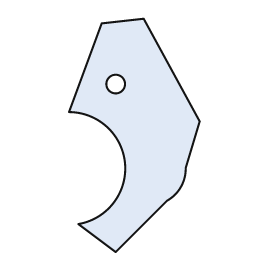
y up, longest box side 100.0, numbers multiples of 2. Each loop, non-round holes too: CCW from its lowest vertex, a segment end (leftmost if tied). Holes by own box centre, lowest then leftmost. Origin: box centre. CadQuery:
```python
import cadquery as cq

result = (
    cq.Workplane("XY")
    .moveTo(-8.0, -50.0)
    .lineTo(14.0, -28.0)
    .threePointArc((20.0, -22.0), (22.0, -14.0))
    .lineTo(28.0, 6.0)
    .lineTo(4.0, 50.0)
    .lineTo(-14.0, 48.0)
    .lineTo(-28.0, 10.0)
    .threePointArc((-4.0, -12.0), (-24.0, -38.0))
    .close()
    .moveTo(-8.0, 22.0)
    .circle(4.0)
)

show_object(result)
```